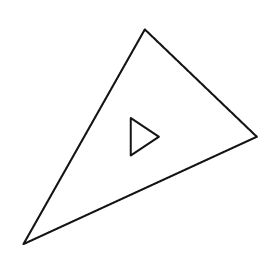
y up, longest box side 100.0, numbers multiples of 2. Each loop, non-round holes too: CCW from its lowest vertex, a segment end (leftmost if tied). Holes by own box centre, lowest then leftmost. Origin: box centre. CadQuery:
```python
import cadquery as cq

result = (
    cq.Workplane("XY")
    .moveTo(-50.0, -46.0)
    .lineTo(50.0, 0.0)
    .lineTo(2.0, 46.0)
    .close()
    .moveTo(-4.0, -8.0)
    .lineTo(8.0, 0.0)
    .lineTo(-4.0, 8.0)
    .close()
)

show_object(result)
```